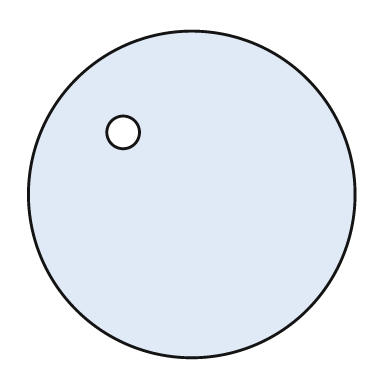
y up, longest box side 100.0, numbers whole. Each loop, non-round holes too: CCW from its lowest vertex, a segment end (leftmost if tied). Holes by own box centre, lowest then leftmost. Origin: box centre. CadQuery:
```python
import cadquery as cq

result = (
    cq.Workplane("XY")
    .moveTo(0.0, 0.0)
    .circle(50.0)
    .moveTo(-21.0, 19.0)
    .circle(5.0)
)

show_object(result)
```